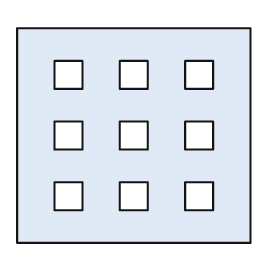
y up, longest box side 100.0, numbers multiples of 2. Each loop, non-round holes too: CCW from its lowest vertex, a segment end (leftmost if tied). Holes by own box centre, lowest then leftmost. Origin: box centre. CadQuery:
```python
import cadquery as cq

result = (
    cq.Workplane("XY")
    .moveTo(-50.0, -46.0)
    .lineTo(50.0, -46.0)
    .lineTo(50.0, 46.0)
    .lineTo(-50.0, 46.0)
    .close()
    .moveTo(-34.0, -32.0)
    .lineTo(-22.0, -32.0)
    .lineTo(-22.0, -20.0)
    .lineTo(-34.0, -20.0)
    .close()
    .moveTo(-6.0, -32.0)
    .lineTo(6.0, -32.0)
    .lineTo(6.0, -20.0)
    .lineTo(-6.0, -20.0)
    .close()
    .moveTo(22.0, -32.0)
    .lineTo(34.0, -32.0)
    .lineTo(34.0, -20.0)
    .lineTo(22.0, -20.0)
    .close()
    .moveTo(-34.0, -6.0)
    .lineTo(-22.0, -6.0)
    .lineTo(-22.0, 6.0)
    .lineTo(-34.0, 6.0)
    .close()
    .moveTo(-6.0, -6.0)
    .lineTo(6.0, -6.0)
    .lineTo(6.0, 6.0)
    .lineTo(-6.0, 6.0)
    .close()
    .moveTo(22.0, -6.0)
    .lineTo(34.0, -6.0)
    .lineTo(34.0, 6.0)
    .lineTo(22.0, 6.0)
    .close()
    .moveTo(-34.0, 20.0)
    .lineTo(-22.0, 20.0)
    .lineTo(-22.0, 32.0)
    .lineTo(-34.0, 32.0)
    .close()
    .moveTo(-6.0, 20.0)
    .lineTo(6.0, 20.0)
    .lineTo(6.0, 32.0)
    .lineTo(-6.0, 32.0)
    .close()
    .moveTo(22.0, 20.0)
    .lineTo(34.0, 20.0)
    .lineTo(34.0, 32.0)
    .lineTo(22.0, 32.0)
    .close()
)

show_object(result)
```